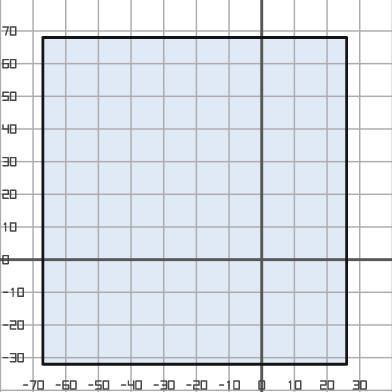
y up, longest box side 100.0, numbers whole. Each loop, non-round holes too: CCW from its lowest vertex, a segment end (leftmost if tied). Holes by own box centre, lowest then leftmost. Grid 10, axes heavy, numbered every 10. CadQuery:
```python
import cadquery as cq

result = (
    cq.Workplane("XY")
    .moveTo(-67.0, -32.0)
    .lineTo(26.0, -32.0)
    .lineTo(26.0, 68.0)
    .lineTo(-67.0, 68.0)
    .close()
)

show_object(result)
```